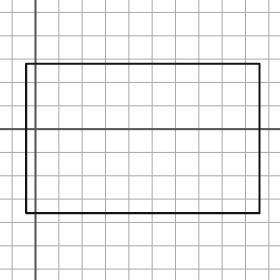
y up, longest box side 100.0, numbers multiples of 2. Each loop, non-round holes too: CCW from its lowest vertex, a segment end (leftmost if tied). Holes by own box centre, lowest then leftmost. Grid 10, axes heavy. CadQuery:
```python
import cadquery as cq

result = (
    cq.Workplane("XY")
    .moveTo(-4.0, -36.0)
    .lineTo(96.0, -36.0)
    .lineTo(96.0, 28.0)
    .lineTo(-4.0, 28.0)
    .close()
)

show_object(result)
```